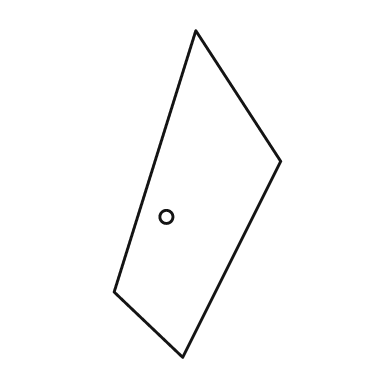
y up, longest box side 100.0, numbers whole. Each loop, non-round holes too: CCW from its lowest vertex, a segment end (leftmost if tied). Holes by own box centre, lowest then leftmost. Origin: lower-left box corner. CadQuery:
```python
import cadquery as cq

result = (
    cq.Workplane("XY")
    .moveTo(21.0, 0.0)
    .lineTo(51.0, 60.0)
    .lineTo(25.0, 100.0)
    .lineTo(0.0, 20.0)
    .close()
    .moveTo(16.0, 43.0)
    .circle(2.0)
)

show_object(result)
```